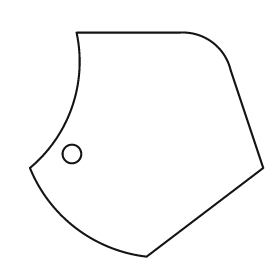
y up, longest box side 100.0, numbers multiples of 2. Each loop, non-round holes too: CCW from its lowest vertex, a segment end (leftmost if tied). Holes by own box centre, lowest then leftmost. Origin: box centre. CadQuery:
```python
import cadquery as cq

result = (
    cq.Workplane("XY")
    .moveTo(0.0, -48.0)
    .lineTo(50.0, -10.0)
    .lineTo(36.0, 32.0)
    .threePointArc((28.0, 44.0), (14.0, 48.0))
    .lineTo(-30.0, 48.0)
    .threePointArc((-32.0, 16.0), (-50.0, -10.0))
    .threePointArc((-30.0, -36.0), (0.0, -48.0))
    .close()
    .moveTo(-32.0, -4.0)
    .circle(4.0)
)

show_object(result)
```